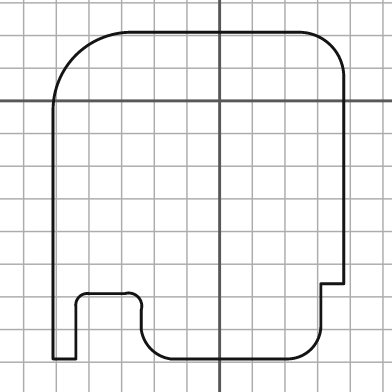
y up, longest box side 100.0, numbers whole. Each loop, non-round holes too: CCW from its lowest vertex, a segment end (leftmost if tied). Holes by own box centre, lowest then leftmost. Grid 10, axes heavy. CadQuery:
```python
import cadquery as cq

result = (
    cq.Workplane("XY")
    .moveTo(-51.0, -79.0)
    .lineTo(-44.0, -79.0)
    .lineTo(-44.0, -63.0)
    .threePointArc((-43.0, -60.0), (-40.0, -59.0))
    .lineTo(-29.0, -59.0)
    .threePointArc((-25.0, -60.0), (-24.0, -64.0))
    .lineTo(-24.0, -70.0)
    .threePointArc((-21.0, -76.0), (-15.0, -79.0))
    .lineTo(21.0, -79.0)
    .threePointArc((28.0, -76.0), (31.0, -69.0))
    .lineTo(31.0, -56.0)
    .lineTo(38.0, -56.0)
    .lineTo(38.0, 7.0)
    .threePointArc((34.0, 17.0), (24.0, 21.0))
    .lineTo(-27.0, 21.0)
    .threePointArc((-44.0, 14.0), (-51.0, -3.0))
    .close()
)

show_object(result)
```